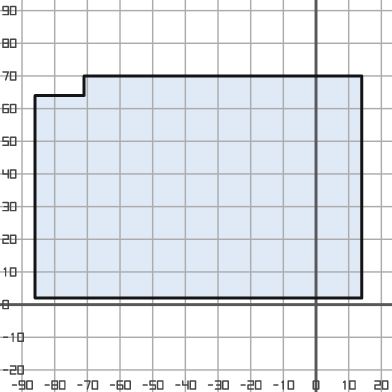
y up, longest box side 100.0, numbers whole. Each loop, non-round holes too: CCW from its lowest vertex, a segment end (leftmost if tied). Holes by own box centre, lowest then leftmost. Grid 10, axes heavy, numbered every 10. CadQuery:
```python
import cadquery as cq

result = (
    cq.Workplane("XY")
    .moveTo(-86.0, 2.0)
    .lineTo(14.0, 2.0)
    .lineTo(14.0, 70.0)
    .lineTo(-71.0, 70.0)
    .lineTo(-71.0, 64.0)
    .lineTo(-86.0, 64.0)
    .close()
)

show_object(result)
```